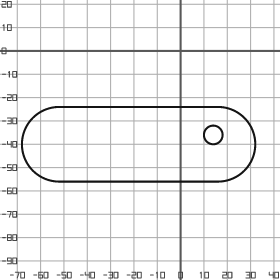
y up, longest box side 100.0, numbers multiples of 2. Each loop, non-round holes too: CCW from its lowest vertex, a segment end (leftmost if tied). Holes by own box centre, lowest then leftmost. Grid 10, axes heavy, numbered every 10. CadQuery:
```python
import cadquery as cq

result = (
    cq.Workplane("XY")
    .moveTo(-52.0, -56.0)
    .lineTo(16.0, -56.0)
    .threePointArc((32.0, -40.0), (16.0, -24.0))
    .lineTo(-52.0, -24.0)
    .threePointArc((-68.0, -40.0), (-52.0, -56.0))
    .close()
    .moveTo(14.0, -36.0)
    .circle(4.0)
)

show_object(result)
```